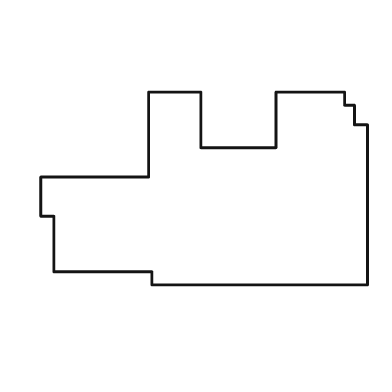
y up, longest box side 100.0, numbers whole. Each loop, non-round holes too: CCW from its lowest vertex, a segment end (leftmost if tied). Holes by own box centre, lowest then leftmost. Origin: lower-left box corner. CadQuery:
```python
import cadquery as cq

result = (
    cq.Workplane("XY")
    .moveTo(34.0, 0.0)
    .lineTo(100.0, 0.0)
    .lineTo(100.0, 49.0)
    .lineTo(96.0, 49.0)
    .lineTo(96.0, 55.0)
    .lineTo(93.0, 55.0)
    .lineTo(93.0, 59.0)
    .lineTo(72.0, 59.0)
    .lineTo(72.0, 42.0)
    .lineTo(49.0, 42.0)
    .lineTo(49.0, 59.0)
    .lineTo(33.0, 59.0)
    .lineTo(33.0, 33.0)
    .lineTo(0.0, 33.0)
    .lineTo(0.0, 21.0)
    .lineTo(4.0, 21.0)
    .lineTo(4.0, 4.0)
    .lineTo(34.0, 4.0)
    .close()
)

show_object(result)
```